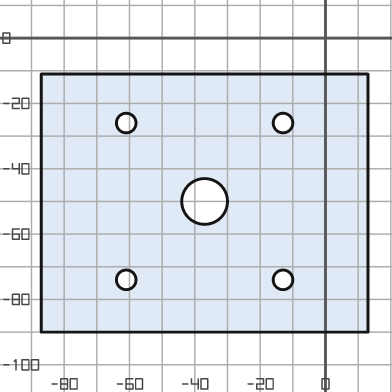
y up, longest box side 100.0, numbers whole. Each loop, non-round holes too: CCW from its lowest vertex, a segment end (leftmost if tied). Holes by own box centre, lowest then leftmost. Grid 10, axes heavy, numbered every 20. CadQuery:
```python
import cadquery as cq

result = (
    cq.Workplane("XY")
    .moveTo(-87.0, -90.0)
    .lineTo(13.0, -90.0)
    .lineTo(13.0, -11.0)
    .lineTo(-87.0, -11.0)
    .close()
    .moveTo(-61.0, -74.0)
    .circle(3.0)
    .moveTo(-13.0, -74.0)
    .circle(3.0)
    .moveTo(-37.0, -50.0)
    .circle(7.0)
    .moveTo(-61.0, -26.0)
    .circle(3.0)
    .moveTo(-13.0, -26.0)
    .circle(3.0)
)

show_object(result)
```